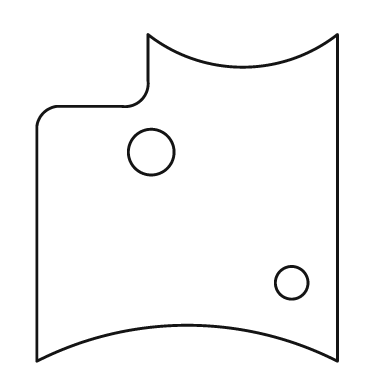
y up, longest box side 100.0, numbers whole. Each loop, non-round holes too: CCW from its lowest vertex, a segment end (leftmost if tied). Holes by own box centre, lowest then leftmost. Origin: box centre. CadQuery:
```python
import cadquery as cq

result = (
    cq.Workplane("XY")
    .moveTo(-46.0, -50.0)
    .threePointArc((0.0, -39.0), (46.0, -50.0))
    .lineTo(46.0, 50.0)
    .threePointArc((17.0, 40.0), (-12.0, 50.0))
    .lineTo(-12.0, 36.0)
    .threePointArc((-14.0, 30.0), (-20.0, 28.0))
    .lineTo(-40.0, 28.0)
    .threePointArc((-44.0, 26.0), (-46.0, 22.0))
    .close()
    .moveTo(32.0, -26.0)
    .circle(5.0)
    .moveTo(-11.0, 14.0)
    .circle(7.0)
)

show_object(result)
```